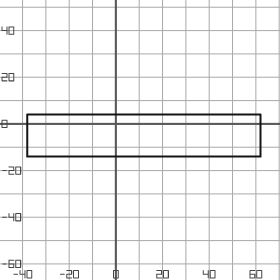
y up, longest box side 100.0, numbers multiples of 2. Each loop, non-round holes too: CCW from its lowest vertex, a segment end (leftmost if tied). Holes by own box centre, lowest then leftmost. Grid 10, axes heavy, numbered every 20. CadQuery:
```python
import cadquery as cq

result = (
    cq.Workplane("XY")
    .moveTo(-38.0, -14.0)
    .lineTo(62.0, -14.0)
    .lineTo(62.0, 4.0)
    .lineTo(-38.0, 4.0)
    .close()
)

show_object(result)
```